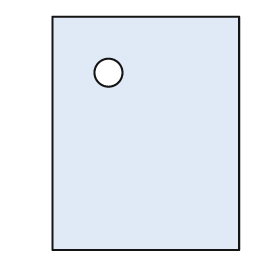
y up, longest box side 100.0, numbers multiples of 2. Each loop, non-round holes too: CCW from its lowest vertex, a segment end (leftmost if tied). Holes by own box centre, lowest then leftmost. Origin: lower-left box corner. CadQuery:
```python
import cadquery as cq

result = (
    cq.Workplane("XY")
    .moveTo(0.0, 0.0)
    .lineTo(80.0, 0.0)
    .lineTo(80.0, 100.0)
    .lineTo(0.0, 100.0)
    .close()
    .moveTo(24.0, 76.0)
    .circle(6.0)
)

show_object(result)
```